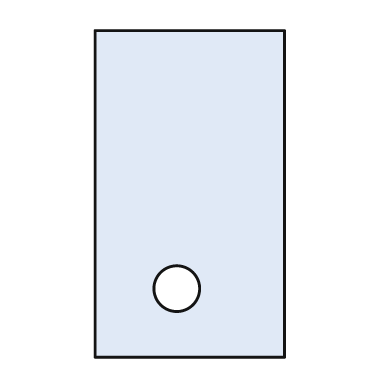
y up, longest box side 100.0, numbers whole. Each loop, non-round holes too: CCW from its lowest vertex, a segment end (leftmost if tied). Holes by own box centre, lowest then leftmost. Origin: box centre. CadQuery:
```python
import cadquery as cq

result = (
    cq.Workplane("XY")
    .moveTo(-29.0, -50.0)
    .lineTo(29.0, -50.0)
    .lineTo(29.0, 50.0)
    .lineTo(-29.0, 50.0)
    .close()
    .moveTo(-4.0, -29.0)
    .circle(7.0)
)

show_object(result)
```